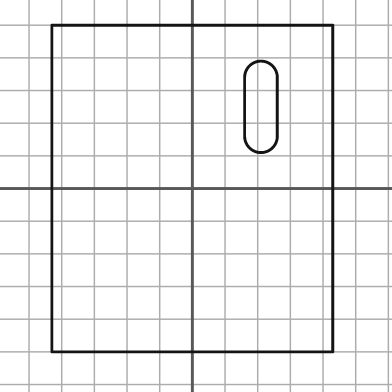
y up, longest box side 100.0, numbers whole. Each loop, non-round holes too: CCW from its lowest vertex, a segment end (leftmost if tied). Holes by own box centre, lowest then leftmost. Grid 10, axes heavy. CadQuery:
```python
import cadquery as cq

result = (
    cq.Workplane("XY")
    .moveTo(-43.0, -50.0)
    .lineTo(43.0, -50.0)
    .lineTo(43.0, 50.0)
    .lineTo(-43.0, 50.0)
    .close()
    .moveTo(16.0, 16.0)
    .threePointArc((21.0, 11.0), (26.0, 16.0))
    .lineTo(26.0, 34.0)
    .threePointArc((21.0, 39.0), (16.0, 34.0))
    .close()
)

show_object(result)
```